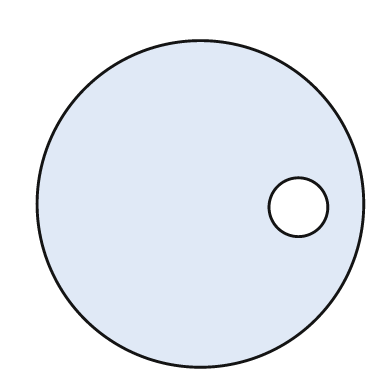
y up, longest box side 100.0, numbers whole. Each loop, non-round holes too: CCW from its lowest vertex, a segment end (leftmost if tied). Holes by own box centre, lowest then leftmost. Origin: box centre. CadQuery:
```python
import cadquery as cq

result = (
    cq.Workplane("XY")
    .moveTo(0.0, 0.0)
    .circle(50.0)
    .moveTo(30.0, -1.0)
    .circle(9.0)
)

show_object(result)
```